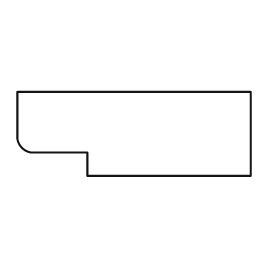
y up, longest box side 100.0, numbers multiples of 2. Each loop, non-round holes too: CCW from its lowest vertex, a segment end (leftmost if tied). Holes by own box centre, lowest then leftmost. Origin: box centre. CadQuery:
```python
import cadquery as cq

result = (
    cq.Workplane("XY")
    .moveTo(-20.0, -18.0)
    .lineTo(50.0, -18.0)
    .lineTo(50.0, 18.0)
    .lineTo(-50.0, 18.0)
    .lineTo(-50.0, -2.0)
    .threePointArc((-48.0, -6.0), (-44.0, -8.0))
    .lineTo(-20.0, -8.0)
    .close()
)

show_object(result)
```